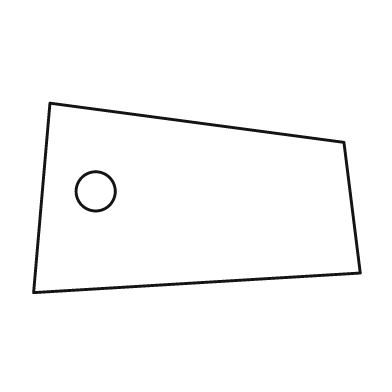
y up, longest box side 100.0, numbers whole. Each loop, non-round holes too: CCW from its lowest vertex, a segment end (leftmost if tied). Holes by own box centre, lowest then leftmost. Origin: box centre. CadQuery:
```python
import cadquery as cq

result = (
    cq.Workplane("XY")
    .moveTo(-50.0, -29.0)
    .lineTo(50.0, -23.0)
    .lineTo(45.0, 17.0)
    .lineTo(-45.0, 29.0)
    .close()
    .moveTo(-31.0, 2.0)
    .circle(6.0)
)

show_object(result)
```